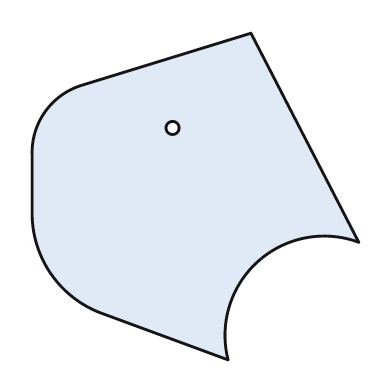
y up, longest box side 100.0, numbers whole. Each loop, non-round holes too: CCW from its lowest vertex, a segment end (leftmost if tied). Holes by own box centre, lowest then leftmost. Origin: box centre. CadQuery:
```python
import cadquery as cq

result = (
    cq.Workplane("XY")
    .moveTo(10.0, -50.0)
    .threePointArc((19.0, -20.0), (50.0, -14.0))
    .lineTo(17.0, 50.0)
    .lineTo(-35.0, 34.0)
    .threePointArc((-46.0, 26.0), (-50.0, 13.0))
    .lineTo(-50.0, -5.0)
    .threePointArc((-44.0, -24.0), (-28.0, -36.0))
    .close()
    .moveTo(-7.0, 21.0)
    .circle(2.0)
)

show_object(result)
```